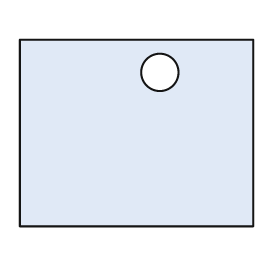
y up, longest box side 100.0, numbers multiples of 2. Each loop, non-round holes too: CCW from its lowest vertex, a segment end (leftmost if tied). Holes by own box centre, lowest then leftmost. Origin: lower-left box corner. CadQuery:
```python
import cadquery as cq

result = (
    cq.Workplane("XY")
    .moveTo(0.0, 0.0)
    .lineTo(100.0, 0.0)
    .lineTo(100.0, 80.0)
    .lineTo(0.0, 80.0)
    .close()
    .moveTo(60.0, 66.0)
    .circle(8.0)
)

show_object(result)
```